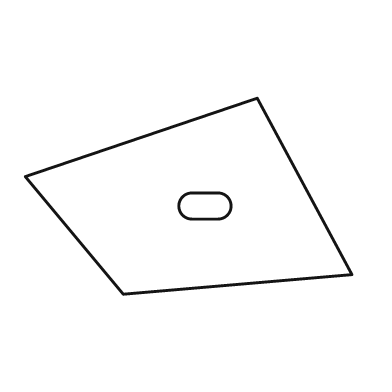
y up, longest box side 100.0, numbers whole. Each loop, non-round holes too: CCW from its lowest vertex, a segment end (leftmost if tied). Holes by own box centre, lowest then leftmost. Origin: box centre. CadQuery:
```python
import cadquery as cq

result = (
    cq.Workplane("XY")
    .moveTo(-20.0, -30.0)
    .lineTo(50.0, -24.0)
    .lineTo(21.0, 30.0)
    .lineTo(-50.0, 6.0)
    .close()
    .moveTo(1.0, -7.0)
    .lineTo(9.0, -7.0)
    .threePointArc((13.0, -3.0), (9.0, 1.0))
    .lineTo(1.0, 1.0)
    .threePointArc((-3.0, -3.0), (1.0, -7.0))
    .close()
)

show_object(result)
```